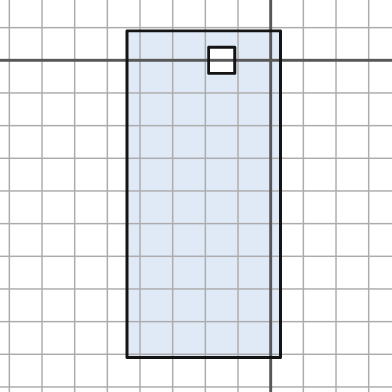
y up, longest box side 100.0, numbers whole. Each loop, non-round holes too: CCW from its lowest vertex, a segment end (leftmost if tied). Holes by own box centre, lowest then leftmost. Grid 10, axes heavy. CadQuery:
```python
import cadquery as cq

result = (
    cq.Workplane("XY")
    .moveTo(-44.0, -91.0)
    .lineTo(3.0, -91.0)
    .lineTo(3.0, 9.0)
    .lineTo(-44.0, 9.0)
    .close()
    .moveTo(-19.0, -4.0)
    .lineTo(-11.0, -4.0)
    .lineTo(-11.0, 4.0)
    .lineTo(-19.0, 4.0)
    .close()
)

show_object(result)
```